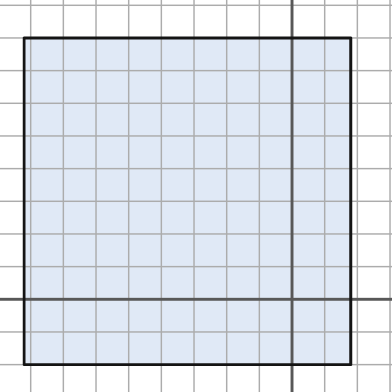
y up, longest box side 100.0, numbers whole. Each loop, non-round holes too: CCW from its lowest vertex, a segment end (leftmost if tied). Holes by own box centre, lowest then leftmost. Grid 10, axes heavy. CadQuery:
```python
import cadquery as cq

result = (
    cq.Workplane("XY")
    .moveTo(-82.0, -20.0)
    .lineTo(18.0, -20.0)
    .lineTo(18.0, 80.0)
    .lineTo(-82.0, 80.0)
    .close()
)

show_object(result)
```